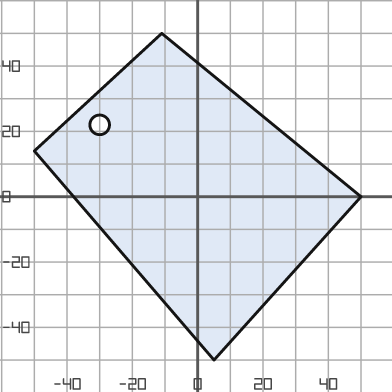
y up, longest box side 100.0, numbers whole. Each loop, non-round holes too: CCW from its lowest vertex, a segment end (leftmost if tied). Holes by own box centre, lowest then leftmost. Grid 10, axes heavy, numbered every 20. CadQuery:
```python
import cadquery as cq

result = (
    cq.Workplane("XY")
    .moveTo(5.0, -50.0)
    .lineTo(50.0, 0.0)
    .lineTo(-11.0, 50.0)
    .lineTo(-50.0, 14.0)
    .close()
    .moveTo(-30.0, 22.0)
    .circle(3.0)
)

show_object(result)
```